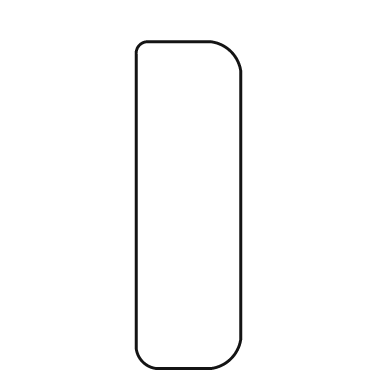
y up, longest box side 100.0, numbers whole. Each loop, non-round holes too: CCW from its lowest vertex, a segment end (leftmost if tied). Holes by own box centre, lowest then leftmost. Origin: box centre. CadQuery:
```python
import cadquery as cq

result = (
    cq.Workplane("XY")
    .moveTo(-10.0, -50.0)
    .lineTo(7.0, -50.0)
    .threePointArc((13.0, -47.0), (16.0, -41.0))
    .lineTo(16.0, 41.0)
    .threePointArc((13.0, 47.0), (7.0, 50.0))
    .lineTo(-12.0, 50.0)
    .threePointArc((-15.0, 49.0), (-16.0, 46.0))
    .lineTo(-16.0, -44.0)
    .threePointArc((-14.0, -48.0), (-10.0, -50.0))
    .close()
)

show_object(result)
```